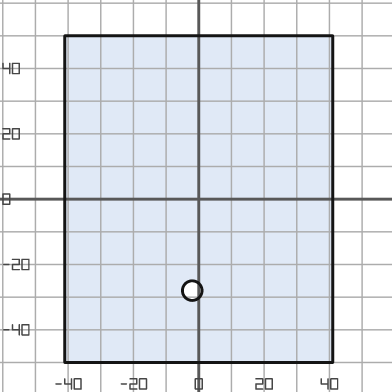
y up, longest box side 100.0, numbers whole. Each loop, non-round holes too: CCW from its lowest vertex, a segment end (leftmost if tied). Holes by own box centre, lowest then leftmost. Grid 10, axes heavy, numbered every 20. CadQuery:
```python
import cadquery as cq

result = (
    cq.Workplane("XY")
    .moveTo(-41.0, -50.0)
    .lineTo(41.0, -50.0)
    .lineTo(41.0, 50.0)
    .lineTo(-41.0, 50.0)
    .close()
    .moveTo(-2.0, -28.0)
    .circle(3.0)
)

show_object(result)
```